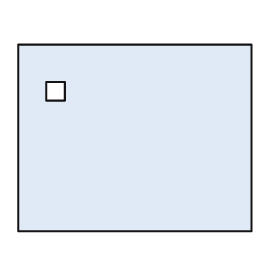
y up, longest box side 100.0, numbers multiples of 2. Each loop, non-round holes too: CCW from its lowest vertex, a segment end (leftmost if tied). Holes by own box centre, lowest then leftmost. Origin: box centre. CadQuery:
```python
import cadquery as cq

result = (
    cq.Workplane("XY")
    .moveTo(-50.0, -40.0)
    .lineTo(50.0, -40.0)
    .lineTo(50.0, 40.0)
    .lineTo(-50.0, 40.0)
    .close()
    .moveTo(-38.0, 16.0)
    .lineTo(-30.0, 16.0)
    .lineTo(-30.0, 24.0)
    .lineTo(-38.0, 24.0)
    .close()
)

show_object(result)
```